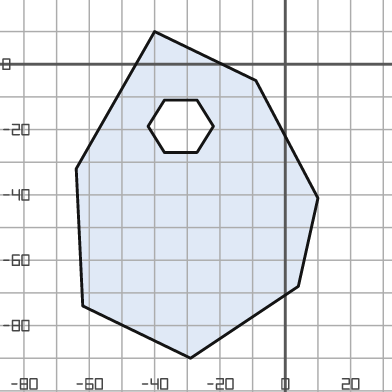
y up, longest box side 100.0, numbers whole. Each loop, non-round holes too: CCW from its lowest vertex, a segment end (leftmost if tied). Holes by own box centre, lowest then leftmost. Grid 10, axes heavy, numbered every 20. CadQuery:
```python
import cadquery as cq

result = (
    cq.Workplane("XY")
    .moveTo(-29.0, -90.0)
    .lineTo(4.0, -68.0)
    .lineTo(10.0, -41.0)
    .lineTo(-9.0, -5.0)
    .lineTo(-40.0, 10.0)
    .lineTo(-64.0, -32.0)
    .lineTo(-62.0, -74.0)
    .close()
    .moveTo(-37.0, -27.0)
    .lineTo(-27.0, -27.0)
    .lineTo(-22.0, -19.0)
    .lineTo(-27.0, -11.0)
    .lineTo(-37.0, -11.0)
    .lineTo(-42.0, -19.0)
    .close()
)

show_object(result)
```